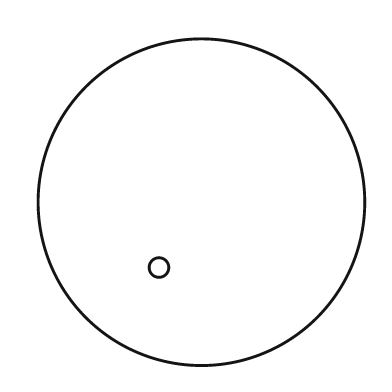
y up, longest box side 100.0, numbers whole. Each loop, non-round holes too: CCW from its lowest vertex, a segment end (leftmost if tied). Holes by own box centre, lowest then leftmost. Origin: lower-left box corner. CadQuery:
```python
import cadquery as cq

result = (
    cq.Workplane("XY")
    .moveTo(50.0, 50.0)
    .circle(50.0)
    .moveTo(37.0, 30.0)
    .circle(3.0)
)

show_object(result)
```